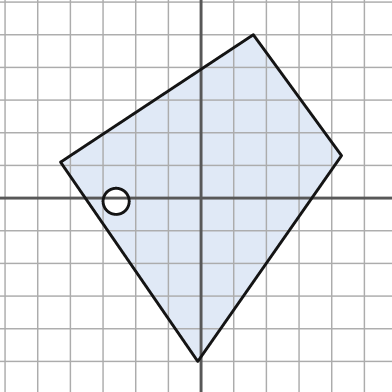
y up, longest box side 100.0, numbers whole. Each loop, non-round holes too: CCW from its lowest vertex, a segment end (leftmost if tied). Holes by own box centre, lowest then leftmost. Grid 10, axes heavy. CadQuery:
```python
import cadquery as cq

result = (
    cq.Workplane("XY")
    .moveTo(-1.0, -50.0)
    .lineTo(43.0, 13.0)
    .lineTo(16.0, 50.0)
    .lineTo(-43.0, 11.0)
    .close()
    .moveTo(-26.0, -1.0)
    .circle(4.0)
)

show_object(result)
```